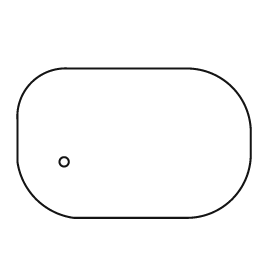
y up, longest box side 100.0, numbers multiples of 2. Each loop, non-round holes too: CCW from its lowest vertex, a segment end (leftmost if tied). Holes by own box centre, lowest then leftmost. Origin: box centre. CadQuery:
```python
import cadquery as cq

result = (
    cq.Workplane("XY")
    .moveTo(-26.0, -32.0)
    .lineTo(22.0, -32.0)
    .threePointArc((42.0, -24.0), (50.0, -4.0))
    .lineTo(50.0, 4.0)
    .threePointArc((42.0, 24.0), (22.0, 32.0))
    .lineTo(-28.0, 32.0)
    .threePointArc((-44.0, 26.0), (-50.0, 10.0))
    .lineTo(-50.0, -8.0)
    .threePointArc((-42.0, -24.0), (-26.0, -32.0))
    .close()
    .moveTo(-30.0, -8.0)
    .circle(2.0)
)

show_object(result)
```